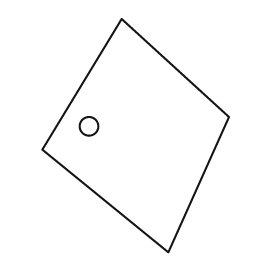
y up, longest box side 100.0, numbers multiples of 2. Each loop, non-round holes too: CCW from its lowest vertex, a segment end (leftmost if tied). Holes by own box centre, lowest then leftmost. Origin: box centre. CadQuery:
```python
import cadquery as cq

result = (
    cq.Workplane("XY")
    .moveTo(14.0, -50.0)
    .lineTo(40.0, 8.0)
    .lineTo(-6.0, 50.0)
    .lineTo(-40.0, -6.0)
    .close()
    .moveTo(-20.0, 4.0)
    .circle(4.0)
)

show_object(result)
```